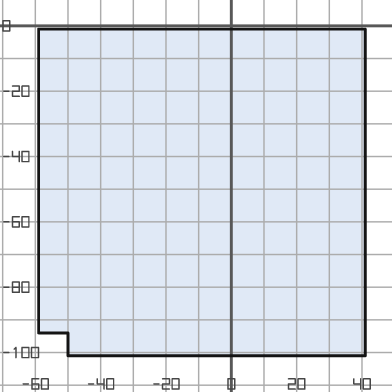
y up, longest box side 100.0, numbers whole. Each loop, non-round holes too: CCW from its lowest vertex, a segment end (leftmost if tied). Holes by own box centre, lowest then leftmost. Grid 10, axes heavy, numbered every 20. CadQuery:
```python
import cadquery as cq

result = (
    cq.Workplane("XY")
    .moveTo(-50.0, -101.0)
    .lineTo(41.0, -101.0)
    .lineTo(41.0, -1.0)
    .lineTo(-59.0, -1.0)
    .lineTo(-59.0, -94.0)
    .lineTo(-50.0, -94.0)
    .close()
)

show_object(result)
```